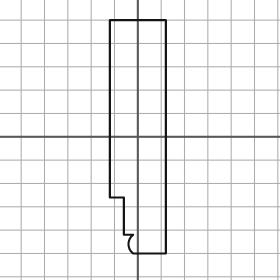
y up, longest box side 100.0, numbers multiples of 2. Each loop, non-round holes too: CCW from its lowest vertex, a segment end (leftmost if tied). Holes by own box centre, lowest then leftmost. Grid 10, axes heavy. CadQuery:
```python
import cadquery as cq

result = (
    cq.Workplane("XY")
    .moveTo(-2.0, -50.0)
    .lineTo(12.0, -50.0)
    .lineTo(12.0, 50.0)
    .lineTo(-12.0, 50.0)
    .lineTo(-12.0, -26.0)
    .lineTo(-6.0, -26.0)
    .lineTo(-6.0, -42.0)
    .lineTo(-2.0, -42.0)
    .threePointArc((-4.0, -46.0), (-2.0, -50.0))
    .close()
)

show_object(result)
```